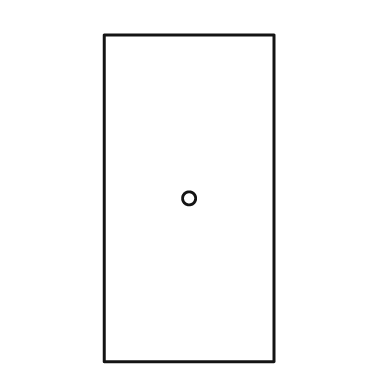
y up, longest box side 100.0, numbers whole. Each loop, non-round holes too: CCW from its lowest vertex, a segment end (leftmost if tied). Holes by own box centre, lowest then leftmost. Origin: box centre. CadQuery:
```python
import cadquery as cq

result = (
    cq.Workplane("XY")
    .moveTo(-26.0, -50.0)
    .lineTo(26.0, -50.0)
    .lineTo(26.0, 50.0)
    .lineTo(-26.0, 50.0)
    .close()
    .moveTo(0.0, 0.0)
    .circle(2.0)
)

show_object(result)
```